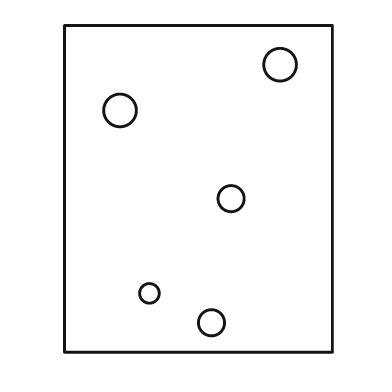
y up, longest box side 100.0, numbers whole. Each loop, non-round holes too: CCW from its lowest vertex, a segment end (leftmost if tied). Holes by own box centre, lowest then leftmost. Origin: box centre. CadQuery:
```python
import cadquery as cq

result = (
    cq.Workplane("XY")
    .moveTo(-41.0, -50.0)
    .lineTo(41.0, -50.0)
    .lineTo(41.0, 50.0)
    .lineTo(-41.0, 50.0)
    .close()
    .moveTo(4.0, -41.0)
    .circle(4.0)
    .moveTo(-15.0, -32.0)
    .circle(3.0)
    .moveTo(10.0, -3.0)
    .circle(4.0)
    .moveTo(-24.0, 24.0)
    .circle(5.0)
    .moveTo(25.0, 38.0)
    .circle(5.0)
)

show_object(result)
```